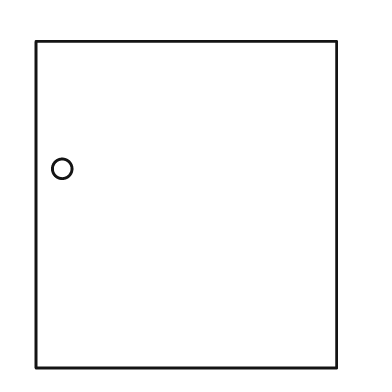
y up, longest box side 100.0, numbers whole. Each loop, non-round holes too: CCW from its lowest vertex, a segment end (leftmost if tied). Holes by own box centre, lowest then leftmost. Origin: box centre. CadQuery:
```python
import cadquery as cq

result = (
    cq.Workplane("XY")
    .moveTo(-46.0, -50.0)
    .lineTo(46.0, -50.0)
    .lineTo(46.0, 50.0)
    .lineTo(-46.0, 50.0)
    .close()
    .moveTo(-38.0, 11.0)
    .circle(3.0)
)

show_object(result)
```